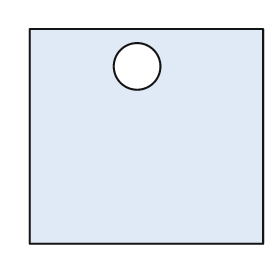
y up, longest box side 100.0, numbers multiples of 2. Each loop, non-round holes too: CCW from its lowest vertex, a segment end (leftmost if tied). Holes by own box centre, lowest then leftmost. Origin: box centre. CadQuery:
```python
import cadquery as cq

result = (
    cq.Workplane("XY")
    .moveTo(-50.0, -46.0)
    .lineTo(50.0, -46.0)
    .lineTo(50.0, 46.0)
    .lineTo(-50.0, 46.0)
    .close()
    .moveTo(-4.0, 30.0)
    .circle(10.0)
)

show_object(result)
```